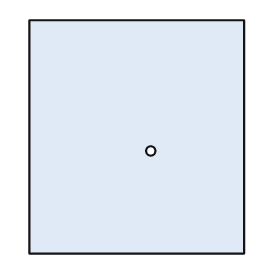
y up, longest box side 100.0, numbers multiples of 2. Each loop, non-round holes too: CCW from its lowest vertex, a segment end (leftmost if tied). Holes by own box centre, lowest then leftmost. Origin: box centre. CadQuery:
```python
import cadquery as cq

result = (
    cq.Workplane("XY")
    .moveTo(-46.0, -50.0)
    .lineTo(46.0, -50.0)
    .lineTo(46.0, 50.0)
    .lineTo(-46.0, 50.0)
    .close()
    .moveTo(6.0, -6.0)
    .circle(2.0)
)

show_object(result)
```